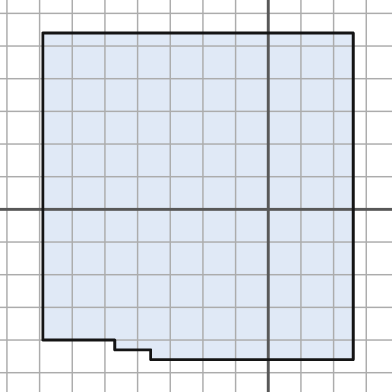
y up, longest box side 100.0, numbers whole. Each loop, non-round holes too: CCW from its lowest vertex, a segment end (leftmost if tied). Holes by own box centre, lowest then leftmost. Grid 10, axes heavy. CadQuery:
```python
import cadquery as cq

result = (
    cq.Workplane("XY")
    .moveTo(-36.0, -46.0)
    .lineTo(26.0, -46.0)
    .lineTo(26.0, 54.0)
    .lineTo(-69.0, 54.0)
    .lineTo(-69.0, -40.0)
    .lineTo(-47.0, -40.0)
    .lineTo(-47.0, -43.0)
    .lineTo(-36.0, -43.0)
    .close()
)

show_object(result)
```